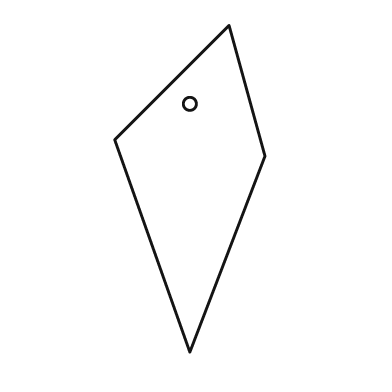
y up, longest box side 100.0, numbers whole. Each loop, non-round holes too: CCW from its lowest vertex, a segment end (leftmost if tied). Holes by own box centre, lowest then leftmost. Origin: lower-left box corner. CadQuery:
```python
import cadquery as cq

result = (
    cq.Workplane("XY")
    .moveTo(23.0, 0.0)
    .lineTo(46.0, 60.0)
    .lineTo(35.0, 100.0)
    .lineTo(0.0, 65.0)
    .close()
    .moveTo(23.0, 76.0)
    .circle(2.0)
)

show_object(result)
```